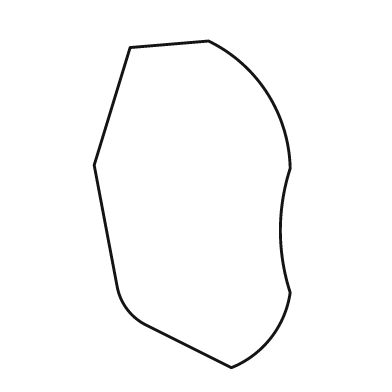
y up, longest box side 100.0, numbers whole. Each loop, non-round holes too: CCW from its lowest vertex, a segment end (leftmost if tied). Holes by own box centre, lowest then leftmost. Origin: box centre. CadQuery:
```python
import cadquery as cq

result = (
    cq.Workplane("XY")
    .moveTo(12.0, -50.0)
    .threePointArc((24.0, -41.0), (30.0, -27.0))
    .threePointArc((27.0, -8.0), (30.0, 11.0))
    .threePointArc((23.0, 34.0), (5.0, 50.0))
    .lineTo(-19.0, 48.0)
    .lineTo(-30.0, 12.0)
    .lineTo(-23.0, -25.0)
    .threePointArc((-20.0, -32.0), (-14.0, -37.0))
    .close()
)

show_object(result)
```